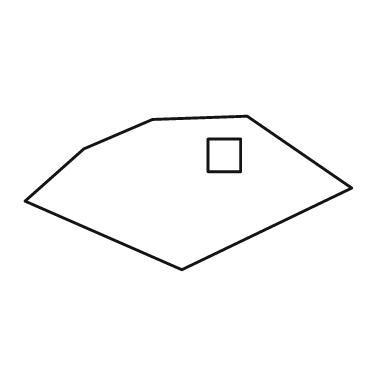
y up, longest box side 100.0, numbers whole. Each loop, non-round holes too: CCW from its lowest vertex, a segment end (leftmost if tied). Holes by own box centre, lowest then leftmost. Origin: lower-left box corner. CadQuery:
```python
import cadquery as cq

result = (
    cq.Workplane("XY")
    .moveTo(48.0, 0.0)
    .lineTo(100.0, 25.0)
    .lineTo(68.0, 47.0)
    .lineTo(39.0, 46.0)
    .lineTo(18.0, 37.0)
    .lineTo(0.0, 21.0)
    .close()
    .moveTo(56.0, 30.0)
    .lineTo(66.0, 30.0)
    .lineTo(66.0, 40.0)
    .lineTo(56.0, 40.0)
    .close()
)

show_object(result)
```